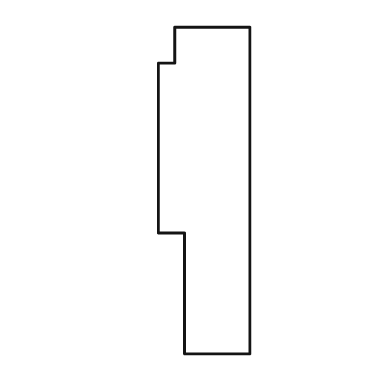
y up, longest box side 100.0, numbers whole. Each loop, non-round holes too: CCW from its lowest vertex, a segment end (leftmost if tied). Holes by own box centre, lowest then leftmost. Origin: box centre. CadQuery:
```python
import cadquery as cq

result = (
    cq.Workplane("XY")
    .moveTo(-6.0, -50.0)
    .lineTo(14.0, -50.0)
    .lineTo(14.0, 50.0)
    .lineTo(-9.0, 50.0)
    .lineTo(-9.0, 39.0)
    .lineTo(-14.0, 39.0)
    .lineTo(-14.0, -13.0)
    .lineTo(-6.0, -13.0)
    .close()
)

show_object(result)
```